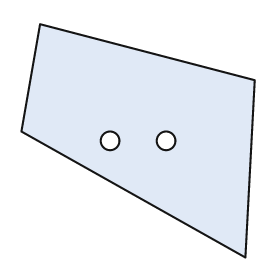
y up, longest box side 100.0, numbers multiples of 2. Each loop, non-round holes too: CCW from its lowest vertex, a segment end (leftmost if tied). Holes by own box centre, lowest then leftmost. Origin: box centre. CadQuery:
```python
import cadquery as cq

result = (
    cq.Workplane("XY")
    .moveTo(46.0, -50.0)
    .lineTo(50.0, 26.0)
    .lineTo(-42.0, 50.0)
    .lineTo(-50.0, 4.0)
    .close()
    .moveTo(-12.0, 0.0)
    .circle(4.0)
    .moveTo(12.0, 0.0)
    .circle(4.0)
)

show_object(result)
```